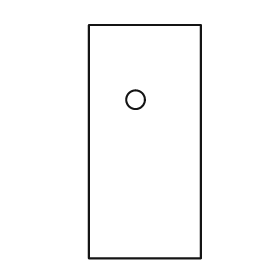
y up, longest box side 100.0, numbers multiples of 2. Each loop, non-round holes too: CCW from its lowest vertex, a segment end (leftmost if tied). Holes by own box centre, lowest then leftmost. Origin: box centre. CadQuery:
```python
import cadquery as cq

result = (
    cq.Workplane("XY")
    .moveTo(-24.0, -50.0)
    .lineTo(24.0, -50.0)
    .lineTo(24.0, 50.0)
    .lineTo(-24.0, 50.0)
    .close()
    .moveTo(-4.0, 18.0)
    .circle(4.0)
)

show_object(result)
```